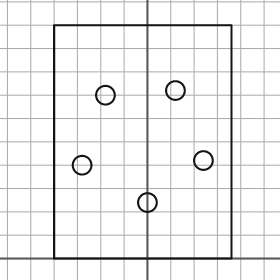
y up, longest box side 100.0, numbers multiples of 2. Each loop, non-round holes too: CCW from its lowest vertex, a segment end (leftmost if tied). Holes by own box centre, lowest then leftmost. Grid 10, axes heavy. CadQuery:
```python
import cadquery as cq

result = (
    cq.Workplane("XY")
    .moveTo(-40.0, 0.0)
    .lineTo(36.0, 0.0)
    .lineTo(36.0, 100.0)
    .lineTo(-40.0, 100.0)
    .close()
    .moveTo(0.0, 24.0)
    .circle(4.0)
    .moveTo(-28.0, 40.0)
    .circle(4.0)
    .moveTo(24.0, 42.0)
    .circle(4.0)
    .moveTo(-18.0, 70.0)
    .circle(4.0)
    .moveTo(12.0, 72.0)
    .circle(4.0)
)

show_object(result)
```